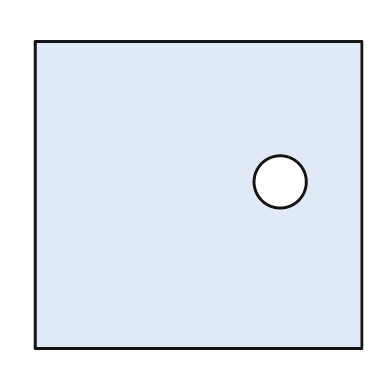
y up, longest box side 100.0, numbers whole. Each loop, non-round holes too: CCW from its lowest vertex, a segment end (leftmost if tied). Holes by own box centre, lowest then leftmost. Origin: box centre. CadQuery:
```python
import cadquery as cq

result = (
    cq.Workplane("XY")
    .moveTo(-50.0, -47.0)
    .lineTo(50.0, -47.0)
    .lineTo(50.0, 47.0)
    .lineTo(-50.0, 47.0)
    .close()
    .moveTo(25.0, 4.0)
    .circle(8.0)
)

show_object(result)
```